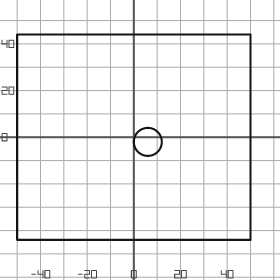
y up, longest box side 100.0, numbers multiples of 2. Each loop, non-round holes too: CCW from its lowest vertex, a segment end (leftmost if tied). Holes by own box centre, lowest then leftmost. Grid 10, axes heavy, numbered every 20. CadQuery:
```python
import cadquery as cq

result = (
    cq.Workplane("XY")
    .moveTo(-50.0, -44.0)
    .lineTo(50.0, -44.0)
    .lineTo(50.0, 44.0)
    .lineTo(-50.0, 44.0)
    .close()
    .moveTo(6.0, -2.0)
    .circle(6.0)
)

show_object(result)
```